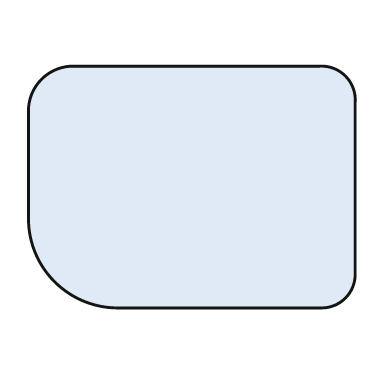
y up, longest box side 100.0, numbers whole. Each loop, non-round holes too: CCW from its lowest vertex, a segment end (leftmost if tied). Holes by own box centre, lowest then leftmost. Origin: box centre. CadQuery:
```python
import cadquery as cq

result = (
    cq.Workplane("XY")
    .moveTo(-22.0, -37.0)
    .lineTo(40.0, -37.0)
    .threePointArc((47.0, -34.0), (50.0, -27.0))
    .lineTo(50.0, 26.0)
    .threePointArc((47.0, 34.0), (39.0, 37.0))
    .lineTo(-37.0, 37.0)
    .threePointArc((-46.0, 33.0), (-50.0, 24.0))
    .lineTo(-50.0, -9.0)
    .threePointArc((-42.0, -29.0), (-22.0, -37.0))
    .close()
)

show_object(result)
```